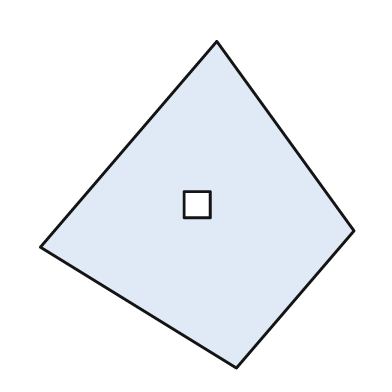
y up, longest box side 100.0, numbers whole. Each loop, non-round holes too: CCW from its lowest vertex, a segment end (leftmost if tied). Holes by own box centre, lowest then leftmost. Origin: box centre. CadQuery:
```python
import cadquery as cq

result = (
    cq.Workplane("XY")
    .moveTo(12.0, -50.0)
    .lineTo(48.0, -8.0)
    .lineTo(6.0, 50.0)
    .lineTo(-48.0, -13.0)
    .close()
    .moveTo(-4.0, -4.0)
    .lineTo(4.0, -4.0)
    .lineTo(4.0, 4.0)
    .lineTo(-4.0, 4.0)
    .close()
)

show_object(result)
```